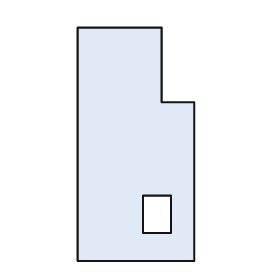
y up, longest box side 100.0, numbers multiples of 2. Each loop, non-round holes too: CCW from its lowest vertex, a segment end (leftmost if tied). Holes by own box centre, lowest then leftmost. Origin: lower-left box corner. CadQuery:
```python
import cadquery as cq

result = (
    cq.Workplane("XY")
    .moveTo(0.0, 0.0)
    .lineTo(50.0, 0.0)
    .lineTo(50.0, 68.0)
    .lineTo(36.0, 68.0)
    .lineTo(36.0, 100.0)
    .lineTo(0.0, 100.0)
    .close()
    .moveTo(28.0, 12.0)
    .lineTo(40.0, 12.0)
    .lineTo(40.0, 28.0)
    .lineTo(28.0, 28.0)
    .close()
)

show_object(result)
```